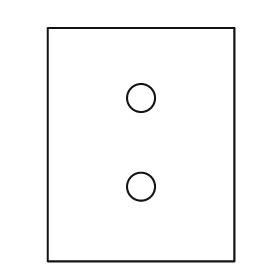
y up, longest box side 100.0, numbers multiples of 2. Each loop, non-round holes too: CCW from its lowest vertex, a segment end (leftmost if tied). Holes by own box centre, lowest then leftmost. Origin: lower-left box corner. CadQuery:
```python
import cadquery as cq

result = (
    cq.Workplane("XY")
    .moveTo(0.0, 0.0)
    .lineTo(80.0, 0.0)
    .lineTo(80.0, 100.0)
    .lineTo(0.0, 100.0)
    .close()
    .moveTo(40.0, 32.0)
    .circle(6.0)
    .moveTo(40.0, 70.0)
    .circle(6.0)
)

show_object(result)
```